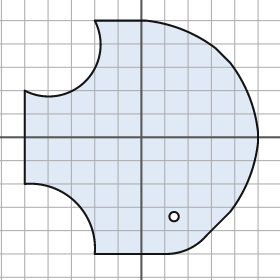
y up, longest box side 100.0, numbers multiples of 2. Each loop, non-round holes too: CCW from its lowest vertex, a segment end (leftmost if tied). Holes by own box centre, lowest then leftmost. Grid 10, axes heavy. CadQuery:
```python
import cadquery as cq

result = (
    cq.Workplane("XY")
    .moveTo(-20.0, -50.0)
    .lineTo(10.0, -50.0)
    .threePointArc((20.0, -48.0), (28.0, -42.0))
    .lineTo(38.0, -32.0)
    .threePointArc((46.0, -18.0), (50.0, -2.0))
    .lineTo(50.0, 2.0)
    .threePointArc((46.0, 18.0), (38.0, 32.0))
    .lineTo(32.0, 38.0)
    .threePointArc((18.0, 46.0), (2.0, 50.0))
    .lineTo(-20.0, 50.0)
    .threePointArc((-24.0, 24.0), (-50.0, 20.0))
    .lineTo(-50.0, -20.0)
    .threePointArc((-28.0, -28.0), (-20.0, -50.0))
    .close()
    .moveTo(14.0, -34.0)
    .circle(2.0)
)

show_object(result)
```